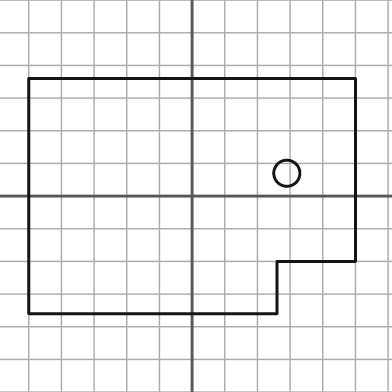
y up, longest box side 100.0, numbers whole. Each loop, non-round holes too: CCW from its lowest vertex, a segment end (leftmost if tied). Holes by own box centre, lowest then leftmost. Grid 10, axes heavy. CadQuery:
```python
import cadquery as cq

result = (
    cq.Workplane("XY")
    .moveTo(-50.0, -36.0)
    .lineTo(26.0, -36.0)
    .lineTo(26.0, -20.0)
    .lineTo(50.0, -20.0)
    .lineTo(50.0, 36.0)
    .lineTo(-50.0, 36.0)
    .close()
    .moveTo(29.0, 7.0)
    .circle(4.0)
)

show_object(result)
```